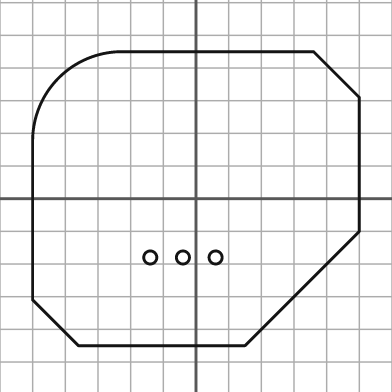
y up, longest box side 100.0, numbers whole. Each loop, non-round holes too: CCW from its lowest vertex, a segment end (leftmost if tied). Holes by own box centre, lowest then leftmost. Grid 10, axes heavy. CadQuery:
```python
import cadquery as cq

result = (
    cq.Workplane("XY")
    .moveTo(-36.0, -45.0)
    .lineTo(15.0, -45.0)
    .lineTo(50.0, -10.0)
    .lineTo(50.0, 31.0)
    .lineTo(36.0, 45.0)
    .lineTo(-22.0, 45.0)
    .threePointArc((-42.0, 37.0), (-50.0, 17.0))
    .lineTo(-50.0, -31.0)
    .close()
    .moveTo(-14.0, -18.0)
    .circle(2.0)
    .moveTo(-4.0, -18.0)
    .circle(2.0)
    .moveTo(6.0, -18.0)
    .circle(2.0)
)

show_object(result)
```